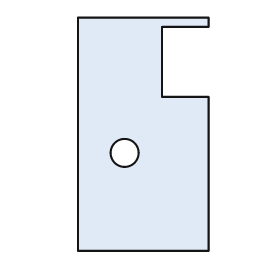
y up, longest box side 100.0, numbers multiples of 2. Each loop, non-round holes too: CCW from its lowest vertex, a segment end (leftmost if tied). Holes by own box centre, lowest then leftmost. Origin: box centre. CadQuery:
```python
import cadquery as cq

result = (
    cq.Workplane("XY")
    .moveTo(-28.0, -50.0)
    .lineTo(28.0, -50.0)
    .lineTo(28.0, 16.0)
    .lineTo(8.0, 16.0)
    .lineTo(8.0, 46.0)
    .lineTo(28.0, 46.0)
    .lineTo(28.0, 50.0)
    .lineTo(-28.0, 50.0)
    .close()
    .moveTo(-8.0, -8.0)
    .circle(6.0)
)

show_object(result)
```